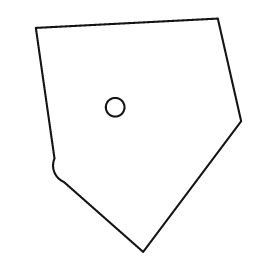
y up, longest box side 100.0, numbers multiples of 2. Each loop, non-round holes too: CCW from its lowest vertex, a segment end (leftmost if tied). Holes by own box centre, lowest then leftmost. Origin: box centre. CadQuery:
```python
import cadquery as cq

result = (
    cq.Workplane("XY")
    .moveTo(2.0, -50.0)
    .lineTo(44.0, 6.0)
    .lineTo(34.0, 50.0)
    .lineTo(-44.0, 46.0)
    .lineTo(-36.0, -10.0)
    .threePointArc((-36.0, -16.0), (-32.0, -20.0))
    .close()
    .moveTo(-10.0, 12.0)
    .circle(4.0)
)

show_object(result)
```